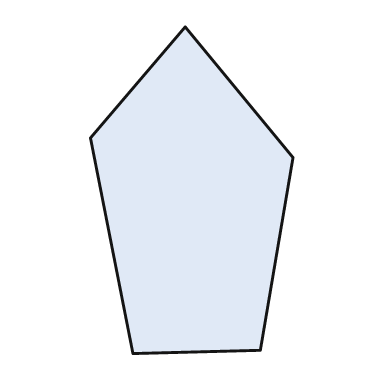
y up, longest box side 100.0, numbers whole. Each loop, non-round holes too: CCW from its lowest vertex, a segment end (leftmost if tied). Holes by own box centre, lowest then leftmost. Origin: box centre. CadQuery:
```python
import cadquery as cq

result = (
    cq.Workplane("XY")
    .moveTo(-18.0, -50.0)
    .lineTo(21.0, -49.0)
    .lineTo(31.0, 10.0)
    .lineTo(-2.0, 50.0)
    .lineTo(-31.0, 16.0)
    .close()
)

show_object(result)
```